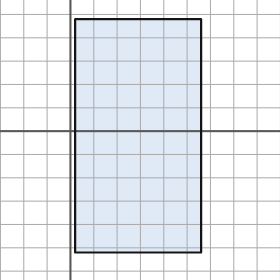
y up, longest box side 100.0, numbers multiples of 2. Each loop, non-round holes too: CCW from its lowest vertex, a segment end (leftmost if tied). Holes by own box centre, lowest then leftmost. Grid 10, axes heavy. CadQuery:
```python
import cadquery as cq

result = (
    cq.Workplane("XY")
    .moveTo(2.0, -52.0)
    .lineTo(56.0, -52.0)
    .lineTo(56.0, 48.0)
    .lineTo(2.0, 48.0)
    .close()
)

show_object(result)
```